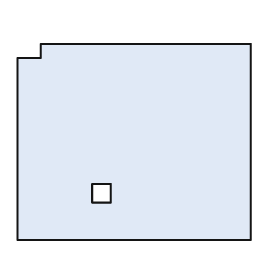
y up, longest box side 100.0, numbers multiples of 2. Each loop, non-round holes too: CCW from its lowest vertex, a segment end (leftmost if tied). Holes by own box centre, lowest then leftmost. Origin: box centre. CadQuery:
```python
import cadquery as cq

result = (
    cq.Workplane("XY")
    .moveTo(-50.0, -42.0)
    .lineTo(50.0, -42.0)
    .lineTo(50.0, 42.0)
    .lineTo(-40.0, 42.0)
    .lineTo(-40.0, 36.0)
    .lineTo(-50.0, 36.0)
    .close()
    .moveTo(-18.0, -26.0)
    .lineTo(-10.0, -26.0)
    .lineTo(-10.0, -18.0)
    .lineTo(-18.0, -18.0)
    .close()
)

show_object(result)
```